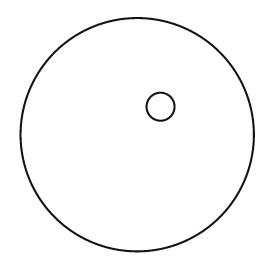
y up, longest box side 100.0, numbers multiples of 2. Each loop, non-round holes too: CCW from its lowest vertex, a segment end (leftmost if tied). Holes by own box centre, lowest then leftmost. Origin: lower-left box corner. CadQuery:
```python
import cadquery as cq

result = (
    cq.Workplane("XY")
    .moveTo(50.0, 50.0)
    .circle(50.0)
    .moveTo(60.0, 62.0)
    .circle(6.0)
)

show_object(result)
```